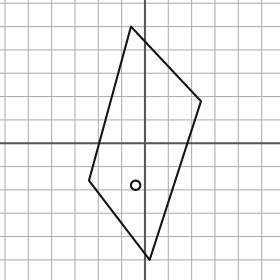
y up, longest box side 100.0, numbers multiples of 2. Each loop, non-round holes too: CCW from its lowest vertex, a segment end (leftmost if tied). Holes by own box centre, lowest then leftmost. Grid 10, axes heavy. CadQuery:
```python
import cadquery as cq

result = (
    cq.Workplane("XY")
    .moveTo(2.0, -50.0)
    .lineTo(24.0, 18.0)
    .lineTo(-6.0, 50.0)
    .lineTo(-24.0, -16.0)
    .close()
    .moveTo(-4.0, -18.0)
    .circle(2.0)
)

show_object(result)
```